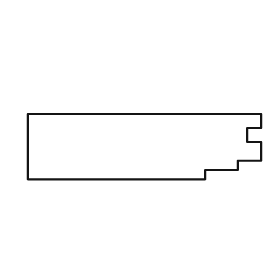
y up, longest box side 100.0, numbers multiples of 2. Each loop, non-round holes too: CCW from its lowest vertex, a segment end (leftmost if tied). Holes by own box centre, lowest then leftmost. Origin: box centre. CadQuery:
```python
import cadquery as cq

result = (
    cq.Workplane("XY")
    .moveTo(-50.0, -14.0)
    .lineTo(26.0, -14.0)
    .lineTo(26.0, -10.0)
    .lineTo(40.0, -10.0)
    .lineTo(40.0, -6.0)
    .lineTo(50.0, -6.0)
    .lineTo(50.0, 2.0)
    .lineTo(44.0, 2.0)
    .lineTo(44.0, 8.0)
    .lineTo(50.0, 8.0)
    .lineTo(50.0, 14.0)
    .lineTo(-50.0, 14.0)
    .close()
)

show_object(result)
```